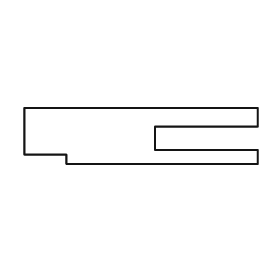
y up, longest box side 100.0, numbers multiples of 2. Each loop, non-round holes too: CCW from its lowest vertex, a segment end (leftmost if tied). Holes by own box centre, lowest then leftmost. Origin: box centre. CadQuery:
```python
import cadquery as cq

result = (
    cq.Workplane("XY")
    .moveTo(-32.0, -12.0)
    .lineTo(50.0, -12.0)
    .lineTo(50.0, -6.0)
    .lineTo(6.0, -6.0)
    .lineTo(6.0, 4.0)
    .lineTo(50.0, 4.0)
    .lineTo(50.0, 12.0)
    .lineTo(-50.0, 12.0)
    .lineTo(-50.0, -8.0)
    .lineTo(-32.0, -8.0)
    .close()
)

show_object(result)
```